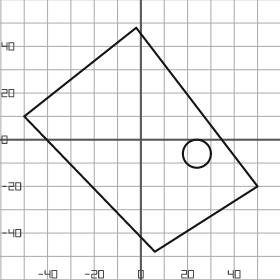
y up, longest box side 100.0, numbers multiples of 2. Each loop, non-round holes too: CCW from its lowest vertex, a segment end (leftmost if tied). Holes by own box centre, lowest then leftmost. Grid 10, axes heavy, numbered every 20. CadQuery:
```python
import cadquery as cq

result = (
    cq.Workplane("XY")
    .moveTo(6.0, -48.0)
    .lineTo(50.0, -20.0)
    .lineTo(-2.0, 48.0)
    .lineTo(-50.0, 10.0)
    .close()
    .moveTo(24.0, -6.0)
    .circle(6.0)
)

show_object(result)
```